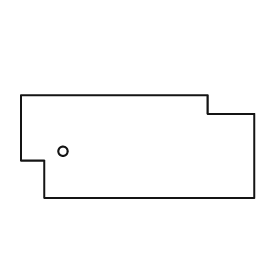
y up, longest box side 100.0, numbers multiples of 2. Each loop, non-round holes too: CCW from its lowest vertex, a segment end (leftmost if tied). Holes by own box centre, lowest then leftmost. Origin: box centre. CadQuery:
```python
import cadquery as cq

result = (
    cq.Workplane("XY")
    .moveTo(-40.0, -22.0)
    .lineTo(50.0, -22.0)
    .lineTo(50.0, 14.0)
    .lineTo(30.0, 14.0)
    .lineTo(30.0, 22.0)
    .lineTo(-50.0, 22.0)
    .lineTo(-50.0, -6.0)
    .lineTo(-40.0, -6.0)
    .close()
    .moveTo(-32.0, -2.0)
    .circle(2.0)
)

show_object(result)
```